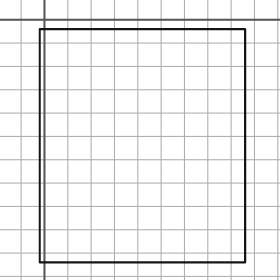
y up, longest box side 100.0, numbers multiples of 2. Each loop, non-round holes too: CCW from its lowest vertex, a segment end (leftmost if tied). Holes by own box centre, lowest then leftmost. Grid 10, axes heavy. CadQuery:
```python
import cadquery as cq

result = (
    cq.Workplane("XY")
    .moveTo(-2.0, -104.0)
    .lineTo(86.0, -104.0)
    .lineTo(86.0, -4.0)
    .lineTo(-2.0, -4.0)
    .close()
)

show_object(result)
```